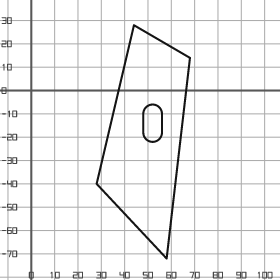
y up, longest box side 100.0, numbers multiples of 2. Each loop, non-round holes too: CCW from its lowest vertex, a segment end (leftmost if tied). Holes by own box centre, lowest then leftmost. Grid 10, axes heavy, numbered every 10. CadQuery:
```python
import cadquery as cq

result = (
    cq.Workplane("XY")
    .moveTo(58.0, -72.0)
    .lineTo(68.0, 14.0)
    .lineTo(44.0, 28.0)
    .lineTo(28.0, -40.0)
    .close()
    .moveTo(48.0, -18.0)
    .threePointArc((52.0, -22.0), (56.0, -18.0))
    .lineTo(56.0, -10.0)
    .threePointArc((52.0, -6.0), (48.0, -10.0))
    .close()
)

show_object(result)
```